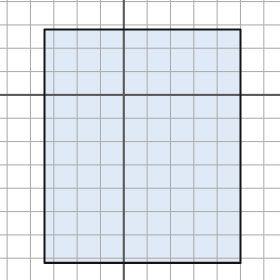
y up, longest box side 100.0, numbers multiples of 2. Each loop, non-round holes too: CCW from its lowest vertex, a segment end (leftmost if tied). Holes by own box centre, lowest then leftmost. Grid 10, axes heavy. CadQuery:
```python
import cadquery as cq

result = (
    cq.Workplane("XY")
    .moveTo(-34.0, -72.0)
    .lineTo(50.0, -72.0)
    .lineTo(50.0, 28.0)
    .lineTo(-34.0, 28.0)
    .close()
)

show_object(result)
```